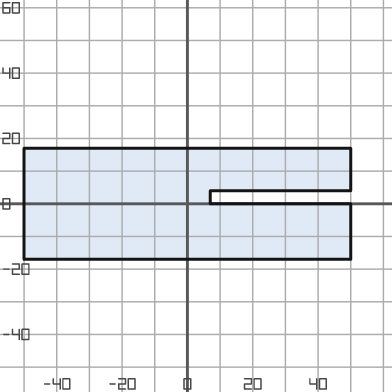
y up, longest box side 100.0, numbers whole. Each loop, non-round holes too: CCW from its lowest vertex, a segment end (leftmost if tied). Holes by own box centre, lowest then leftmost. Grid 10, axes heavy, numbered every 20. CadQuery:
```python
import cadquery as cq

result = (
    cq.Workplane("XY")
    .moveTo(-50.0, -17.0)
    .lineTo(50.0, -17.0)
    .lineTo(50.0, 0.0)
    .lineTo(7.0, 0.0)
    .lineTo(7.0, 4.0)
    .lineTo(50.0, 4.0)
    .lineTo(50.0, 17.0)
    .lineTo(-50.0, 17.0)
    .close()
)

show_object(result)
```